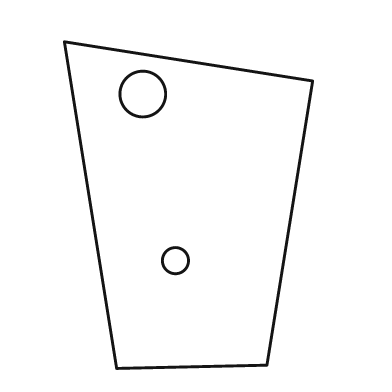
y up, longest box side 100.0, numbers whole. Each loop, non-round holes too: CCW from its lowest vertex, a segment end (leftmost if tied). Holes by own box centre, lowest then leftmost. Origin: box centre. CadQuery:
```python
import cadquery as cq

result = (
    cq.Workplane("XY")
    .moveTo(-22.0, -50.0)
    .lineTo(24.0, -49.0)
    .lineTo(38.0, 38.0)
    .lineTo(-38.0, 50.0)
    .close()
    .moveTo(-4.0, -17.0)
    .circle(4.0)
    .moveTo(-14.0, 34.0)
    .circle(7.0)
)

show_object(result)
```